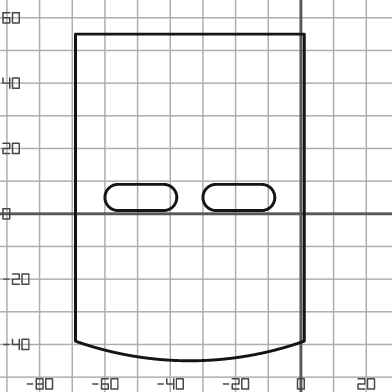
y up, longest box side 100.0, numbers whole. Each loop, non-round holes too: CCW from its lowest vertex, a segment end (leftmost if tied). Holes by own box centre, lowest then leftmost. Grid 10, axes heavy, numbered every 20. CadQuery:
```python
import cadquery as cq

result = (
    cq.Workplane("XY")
    .moveTo(-69.0, -39.0)
    .threePointArc((-34.0, -45.0), (1.0, -39.0))
    .lineTo(1.0, 55.0)
    .lineTo(-69.0, 55.0)
    .close()
    .moveTo(-56.0, 1.0)
    .lineTo(-42.0, 1.0)
    .threePointArc((-38.0, 5.0), (-42.0, 9.0))
    .lineTo(-56.0, 9.0)
    .threePointArc((-60.0, 5.0), (-56.0, 1.0))
    .close()
    .moveTo(-26.0, 1.0)
    .lineTo(-12.0, 1.0)
    .threePointArc((-8.0, 5.0), (-12.0, 9.0))
    .lineTo(-26.0, 9.0)
    .threePointArc((-30.0, 5.0), (-26.0, 1.0))
    .close()
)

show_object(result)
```